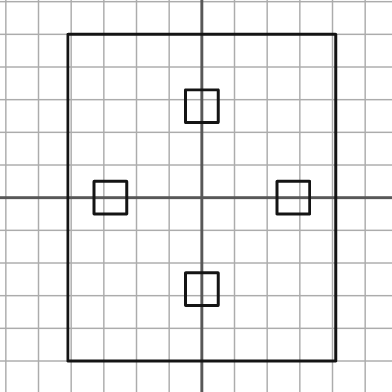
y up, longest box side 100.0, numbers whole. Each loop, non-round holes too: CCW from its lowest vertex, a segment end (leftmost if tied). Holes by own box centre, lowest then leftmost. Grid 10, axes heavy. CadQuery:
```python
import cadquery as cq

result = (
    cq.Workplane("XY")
    .moveTo(-41.0, -50.0)
    .lineTo(41.0, -50.0)
    .lineTo(41.0, 50.0)
    .lineTo(-41.0, 50.0)
    .close()
    .moveTo(-5.0, -33.0)
    .lineTo(5.0, -33.0)
    .lineTo(5.0, -23.0)
    .lineTo(-5.0, -23.0)
    .close()
    .moveTo(-33.0, -5.0)
    .lineTo(-23.0, -5.0)
    .lineTo(-23.0, 5.0)
    .lineTo(-33.0, 5.0)
    .close()
    .moveTo(23.0, -5.0)
    .lineTo(33.0, -5.0)
    .lineTo(33.0, 5.0)
    .lineTo(23.0, 5.0)
    .close()
    .moveTo(-5.0, 23.0)
    .lineTo(5.0, 23.0)
    .lineTo(5.0, 33.0)
    .lineTo(-5.0, 33.0)
    .close()
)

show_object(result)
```